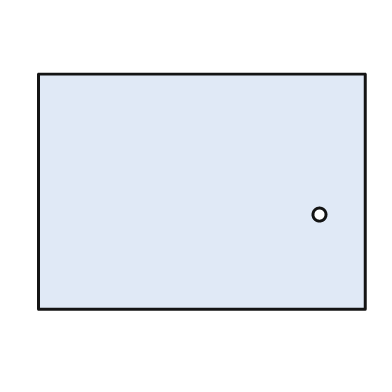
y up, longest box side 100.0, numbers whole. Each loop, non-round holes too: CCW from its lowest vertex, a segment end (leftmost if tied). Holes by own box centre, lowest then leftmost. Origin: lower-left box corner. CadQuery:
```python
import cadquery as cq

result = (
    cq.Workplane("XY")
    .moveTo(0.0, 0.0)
    .lineTo(100.0, 0.0)
    .lineTo(100.0, 72.0)
    .lineTo(0.0, 72.0)
    .close()
    .moveTo(86.0, 29.0)
    .circle(2.0)
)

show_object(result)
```